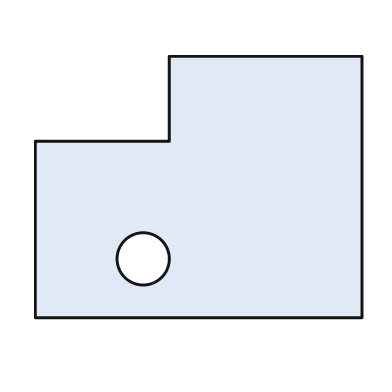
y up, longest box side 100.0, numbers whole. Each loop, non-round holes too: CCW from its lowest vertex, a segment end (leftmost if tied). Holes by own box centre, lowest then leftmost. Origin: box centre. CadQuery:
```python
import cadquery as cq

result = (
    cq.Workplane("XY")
    .moveTo(-50.0, -40.0)
    .lineTo(50.0, -40.0)
    .lineTo(50.0, 40.0)
    .lineTo(-9.0, 40.0)
    .lineTo(-9.0, 14.0)
    .lineTo(-50.0, 14.0)
    .close()
    .moveTo(-17.0, -22.0)
    .circle(8.0)
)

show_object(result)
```